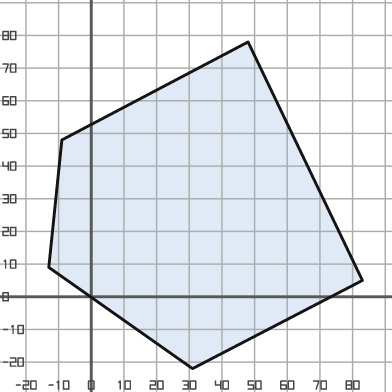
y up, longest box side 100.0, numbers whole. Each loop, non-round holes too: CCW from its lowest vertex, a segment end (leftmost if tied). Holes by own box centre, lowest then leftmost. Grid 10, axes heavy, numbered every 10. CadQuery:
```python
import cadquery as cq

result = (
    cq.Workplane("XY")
    .moveTo(31.0, -22.0)
    .lineTo(83.0, 5.0)
    .lineTo(48.0, 78.0)
    .lineTo(-9.0, 48.0)
    .lineTo(-13.0, 9.0)
    .close()
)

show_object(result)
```